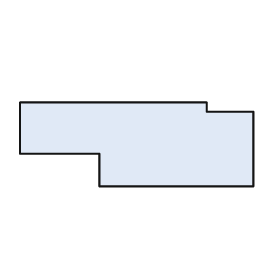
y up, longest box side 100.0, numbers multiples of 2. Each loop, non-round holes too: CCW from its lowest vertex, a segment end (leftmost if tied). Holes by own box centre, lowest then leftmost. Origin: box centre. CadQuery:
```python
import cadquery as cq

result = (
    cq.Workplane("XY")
    .moveTo(-16.0, -18.0)
    .lineTo(50.0, -18.0)
    .lineTo(50.0, 14.0)
    .lineTo(30.0, 14.0)
    .lineTo(30.0, 18.0)
    .lineTo(-50.0, 18.0)
    .lineTo(-50.0, -4.0)
    .lineTo(-16.0, -4.0)
    .close()
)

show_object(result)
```